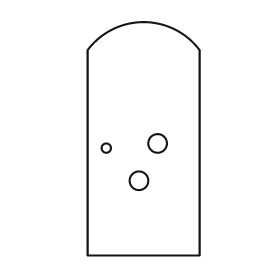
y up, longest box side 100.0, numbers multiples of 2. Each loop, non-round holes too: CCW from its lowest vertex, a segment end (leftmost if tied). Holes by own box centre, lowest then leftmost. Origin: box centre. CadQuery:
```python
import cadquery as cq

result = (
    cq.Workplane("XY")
    .moveTo(-24.0, -50.0)
    .lineTo(24.0, -50.0)
    .lineTo(24.0, 38.0)
    .threePointArc((0.0, 50.0), (-24.0, 38.0))
    .close()
    .moveTo(-2.0, -18.0)
    .circle(4.0)
    .moveTo(-16.0, -4.0)
    .circle(2.0)
    .moveTo(6.0, -2.0)
    .circle(4.0)
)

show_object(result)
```